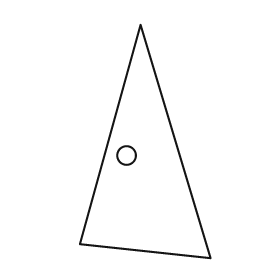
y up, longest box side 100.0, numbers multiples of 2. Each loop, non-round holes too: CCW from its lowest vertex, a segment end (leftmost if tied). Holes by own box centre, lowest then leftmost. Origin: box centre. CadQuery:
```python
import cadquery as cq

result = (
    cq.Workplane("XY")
    .moveTo(28.0, -50.0)
    .lineTo(-2.0, 50.0)
    .lineTo(-28.0, -44.0)
    .close()
    .moveTo(-8.0, -6.0)
    .circle(4.0)
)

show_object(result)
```